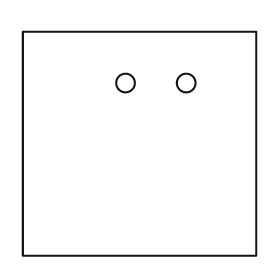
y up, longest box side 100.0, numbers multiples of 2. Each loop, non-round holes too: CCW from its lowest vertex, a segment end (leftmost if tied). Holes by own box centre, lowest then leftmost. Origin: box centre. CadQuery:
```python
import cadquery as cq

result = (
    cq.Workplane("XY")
    .moveTo(-50.0, -48.0)
    .lineTo(50.0, -48.0)
    .lineTo(50.0, 48.0)
    .lineTo(-50.0, 48.0)
    .close()
    .moveTo(-6.0, 26.0)
    .circle(4.0)
    .moveTo(20.0, 26.0)
    .circle(4.0)
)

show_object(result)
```